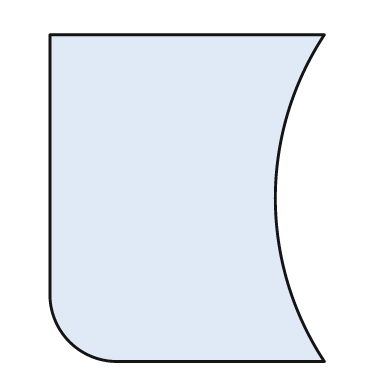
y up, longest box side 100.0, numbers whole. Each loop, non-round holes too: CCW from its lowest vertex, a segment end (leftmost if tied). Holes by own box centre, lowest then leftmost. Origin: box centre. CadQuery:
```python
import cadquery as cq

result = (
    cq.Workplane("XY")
    .moveTo(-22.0, -50.0)
    .lineTo(42.0, -50.0)
    .threePointArc((27.0, 0.0), (42.0, 50.0))
    .lineTo(-42.0, 50.0)
    .lineTo(-42.0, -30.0)
    .threePointArc((-36.0, -44.0), (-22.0, -50.0))
    .close()
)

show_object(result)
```